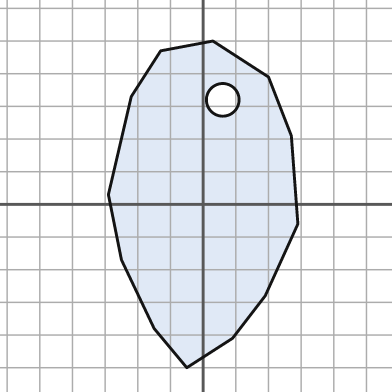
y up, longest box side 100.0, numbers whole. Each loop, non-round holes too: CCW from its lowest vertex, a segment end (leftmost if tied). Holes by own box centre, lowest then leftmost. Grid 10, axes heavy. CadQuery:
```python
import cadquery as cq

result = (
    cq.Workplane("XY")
    .moveTo(-5.0, -50.0)
    .lineTo(9.0, -41.0)
    .lineTo(19.0, -28.0)
    .lineTo(29.0, -6.0)
    .lineTo(27.0, 21.0)
    .lineTo(20.0, 39.0)
    .lineTo(3.0, 50.0)
    .lineTo(-13.0, 47.0)
    .lineTo(-22.0, 33.0)
    .lineTo(-29.0, 3.0)
    .lineTo(-25.0, -17.0)
    .lineTo(-15.0, -38.0)
    .close()
    .moveTo(6.0, 32.0)
    .circle(5.0)
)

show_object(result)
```